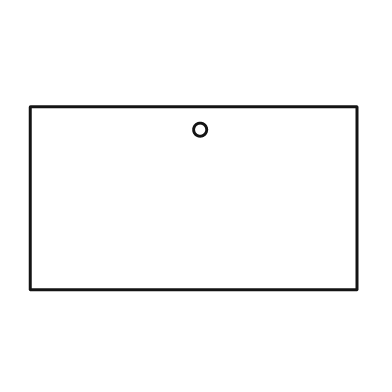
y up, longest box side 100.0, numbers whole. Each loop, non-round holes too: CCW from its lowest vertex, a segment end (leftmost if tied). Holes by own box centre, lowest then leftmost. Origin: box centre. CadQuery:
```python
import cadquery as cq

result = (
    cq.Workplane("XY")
    .moveTo(-50.0, -28.0)
    .lineTo(50.0, -28.0)
    .lineTo(50.0, 28.0)
    .lineTo(-50.0, 28.0)
    .close()
    .moveTo(2.0, 21.0)
    .circle(2.0)
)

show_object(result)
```